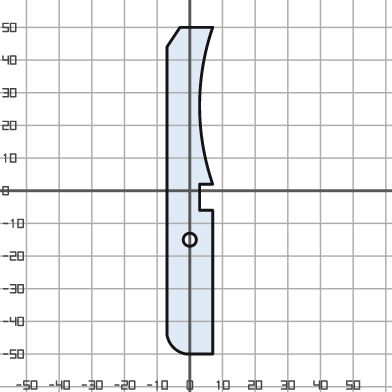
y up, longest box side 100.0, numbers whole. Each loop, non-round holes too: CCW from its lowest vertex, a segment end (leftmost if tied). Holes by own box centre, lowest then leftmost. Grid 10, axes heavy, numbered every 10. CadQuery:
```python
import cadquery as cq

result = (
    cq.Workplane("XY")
    .moveTo(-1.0, -50.0)
    .lineTo(7.0, -50.0)
    .lineTo(7.0, -6.0)
    .lineTo(3.0, -6.0)
    .lineTo(3.0, 2.0)
    .lineTo(7.0, 2.0)
    .threePointArc((3.0, 26.0), (7.0, 50.0))
    .lineTo(-3.0, 50.0)
    .lineTo(-7.0, 44.0)
    .lineTo(-7.0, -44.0)
    .threePointArc((-5.0, -48.0), (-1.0, -50.0))
    .close()
    .moveTo(0.0, -15.0)
    .circle(2.0)
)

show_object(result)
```